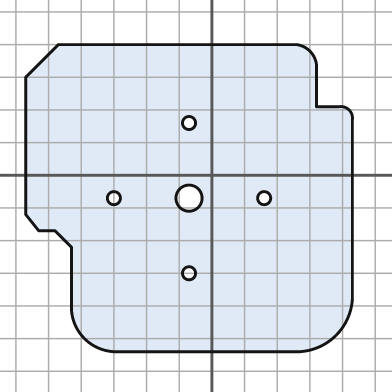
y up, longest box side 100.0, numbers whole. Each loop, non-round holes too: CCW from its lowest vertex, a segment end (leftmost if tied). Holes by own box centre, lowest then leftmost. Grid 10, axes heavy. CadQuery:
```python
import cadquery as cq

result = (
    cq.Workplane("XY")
    .moveTo(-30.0, -54.0)
    .lineTo(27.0, -54.0)
    .threePointArc((38.0, -49.0), (43.0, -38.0))
    .lineTo(43.0, 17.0)
    .threePointArc((42.0, 20.0), (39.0, 21.0))
    .lineTo(32.0, 21.0)
    .lineTo(32.0, 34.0)
    .threePointArc((30.0, 38.0), (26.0, 40.0))
    .lineTo(-47.0, 40.0)
    .lineTo(-57.0, 30.0)
    .lineTo(-57.0, -12.0)
    .lineTo(-53.0, -17.0)
    .lineTo(-48.0, -17.0)
    .lineTo(-43.0, -22.0)
    .lineTo(-43.0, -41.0)
    .threePointArc((-39.0, -50.0), (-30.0, -54.0))
    .close()
    .moveTo(-7.0, -30.0)
    .circle(2.0)
    .moveTo(-30.0, -7.0)
    .circle(2.0)
    .moveTo(-7.0, -7.0)
    .circle(4.0)
    .moveTo(16.0, -7.0)
    .circle(2.0)
    .moveTo(-7.0, 16.0)
    .circle(2.0)
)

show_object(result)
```